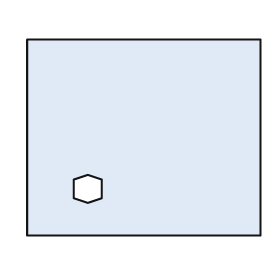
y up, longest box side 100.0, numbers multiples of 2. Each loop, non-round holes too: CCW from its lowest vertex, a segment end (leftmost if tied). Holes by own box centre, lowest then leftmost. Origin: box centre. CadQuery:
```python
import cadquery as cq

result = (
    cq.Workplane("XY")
    .moveTo(-50.0, -42.0)
    .lineTo(50.0, -42.0)
    .lineTo(50.0, 42.0)
    .lineTo(-50.0, 42.0)
    .close()
    .moveTo(-24.0, -28.0)
    .lineTo(-18.0, -26.0)
    .lineTo(-18.0, -18.0)
    .lineTo(-24.0, -16.0)
    .lineTo(-30.0, -18.0)
    .lineTo(-30.0, -26.0)
    .close()
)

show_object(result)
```